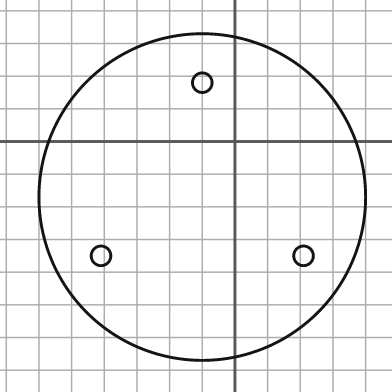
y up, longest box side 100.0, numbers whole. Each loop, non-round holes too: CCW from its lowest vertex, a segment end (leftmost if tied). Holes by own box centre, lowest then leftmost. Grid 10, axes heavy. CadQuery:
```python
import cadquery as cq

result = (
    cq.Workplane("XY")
    .moveTo(-10.0, -17.0)
    .circle(50.0)
    .moveTo(-41.0, -35.0)
    .circle(3.0)
    .moveTo(21.0, -35.0)
    .circle(3.0)
    .moveTo(-10.0, 18.0)
    .circle(3.0)
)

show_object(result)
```